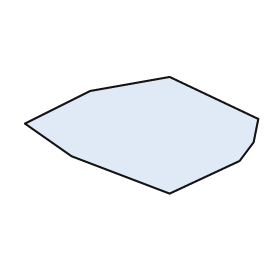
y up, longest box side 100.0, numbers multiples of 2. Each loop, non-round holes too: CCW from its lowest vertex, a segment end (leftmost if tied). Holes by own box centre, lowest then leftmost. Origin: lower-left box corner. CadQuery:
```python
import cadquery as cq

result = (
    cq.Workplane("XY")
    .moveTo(62.0, 0.0)
    .lineTo(92.0, 14.0)
    .lineTo(98.0, 22.0)
    .lineTo(100.0, 32.0)
    .lineTo(62.0, 50.0)
    .lineTo(28.0, 44.0)
    .lineTo(0.0, 30.0)
    .lineTo(20.0, 16.0)
    .close()
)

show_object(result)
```